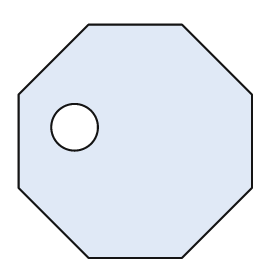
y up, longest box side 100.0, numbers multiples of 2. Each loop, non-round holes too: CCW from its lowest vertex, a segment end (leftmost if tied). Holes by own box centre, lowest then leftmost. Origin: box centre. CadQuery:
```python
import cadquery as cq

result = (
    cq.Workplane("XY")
    .moveTo(-20.0, -50.0)
    .lineTo(20.0, -50.0)
    .lineTo(50.0, -20.0)
    .lineTo(50.0, 20.0)
    .lineTo(20.0, 50.0)
    .lineTo(-20.0, 50.0)
    .lineTo(-50.0, 20.0)
    .lineTo(-50.0, -20.0)
    .close()
    .moveTo(-26.0, 6.0)
    .circle(10.0)
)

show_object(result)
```